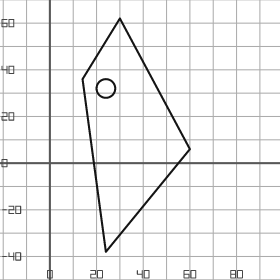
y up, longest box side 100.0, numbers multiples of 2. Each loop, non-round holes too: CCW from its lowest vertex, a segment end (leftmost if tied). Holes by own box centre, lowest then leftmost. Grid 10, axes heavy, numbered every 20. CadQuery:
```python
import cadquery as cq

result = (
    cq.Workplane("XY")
    .moveTo(24.0, -38.0)
    .lineTo(60.0, 6.0)
    .lineTo(30.0, 62.0)
    .lineTo(14.0, 36.0)
    .close()
    .moveTo(24.0, 32.0)
    .circle(4.0)
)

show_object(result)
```